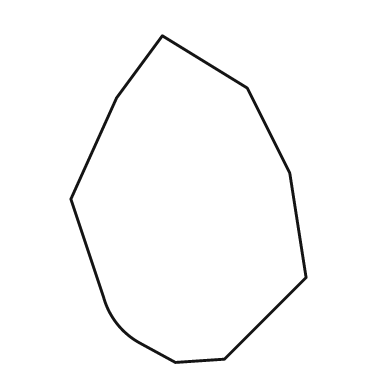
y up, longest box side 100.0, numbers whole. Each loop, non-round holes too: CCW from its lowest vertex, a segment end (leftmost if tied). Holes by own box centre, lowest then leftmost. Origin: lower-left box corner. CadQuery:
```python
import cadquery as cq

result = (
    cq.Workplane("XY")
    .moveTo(32.0, 0.0)
    .lineTo(47.0, 1.0)
    .lineTo(72.0, 26.0)
    .lineTo(67.0, 58.0)
    .lineTo(54.0, 84.0)
    .lineTo(28.0, 100.0)
    .lineTo(14.0, 81.0)
    .lineTo(0.0, 50.0)
    .lineTo(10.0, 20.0)
    .threePointArc((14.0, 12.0), (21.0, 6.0))
    .close()
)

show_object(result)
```